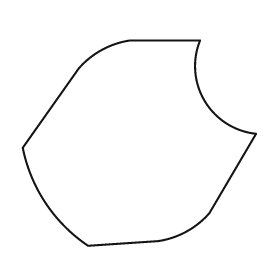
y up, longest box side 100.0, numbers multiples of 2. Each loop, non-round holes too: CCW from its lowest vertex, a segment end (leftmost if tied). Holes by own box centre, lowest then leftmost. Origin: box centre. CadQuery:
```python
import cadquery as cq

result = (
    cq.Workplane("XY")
    .moveTo(-22.0, -44.0)
    .lineTo(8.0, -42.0)
    .threePointArc((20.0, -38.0), (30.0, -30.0))
    .lineTo(50.0, 4.0)
    .threePointArc((28.0, 18.0), (26.0, 44.0))
    .lineTo(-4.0, 44.0)
    .threePointArc((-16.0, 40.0), (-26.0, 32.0))
    .lineTo(-50.0, -2.0)
    .threePointArc((-40.0, -26.0), (-22.0, -44.0))
    .close()
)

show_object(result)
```